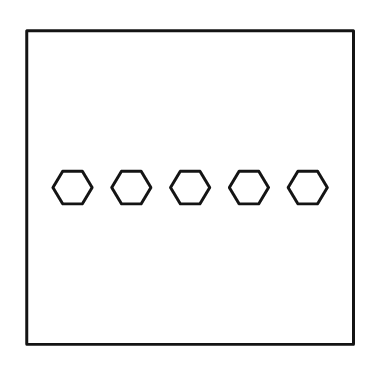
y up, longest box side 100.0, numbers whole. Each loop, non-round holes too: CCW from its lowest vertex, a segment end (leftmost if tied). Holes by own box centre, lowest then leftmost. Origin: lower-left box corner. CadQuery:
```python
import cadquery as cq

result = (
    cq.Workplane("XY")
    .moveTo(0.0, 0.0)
    .lineTo(100.0, 0.0)
    .lineTo(100.0, 96.0)
    .lineTo(0.0, 96.0)
    .close()
    .moveTo(11.0, 43.0)
    .lineTo(17.0, 43.0)
    .lineTo(20.0, 48.0)
    .lineTo(17.0, 53.0)
    .lineTo(11.0, 53.0)
    .lineTo(8.0, 48.0)
    .close()
    .moveTo(29.0, 43.0)
    .lineTo(35.0, 43.0)
    .lineTo(38.0, 48.0)
    .lineTo(35.0, 53.0)
    .lineTo(29.0, 53.0)
    .lineTo(26.0, 48.0)
    .close()
    .moveTo(47.0, 43.0)
    .lineTo(53.0, 43.0)
    .lineTo(56.0, 48.0)
    .lineTo(53.0, 53.0)
    .lineTo(47.0, 53.0)
    .lineTo(44.0, 48.0)
    .close()
    .moveTo(65.0, 43.0)
    .lineTo(71.0, 43.0)
    .lineTo(74.0, 48.0)
    .lineTo(71.0, 53.0)
    .lineTo(65.0, 53.0)
    .lineTo(62.0, 48.0)
    .close()
    .moveTo(83.0, 43.0)
    .lineTo(89.0, 43.0)
    .lineTo(92.0, 48.0)
    .lineTo(89.0, 53.0)
    .lineTo(83.0, 53.0)
    .lineTo(80.0, 48.0)
    .close()
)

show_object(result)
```